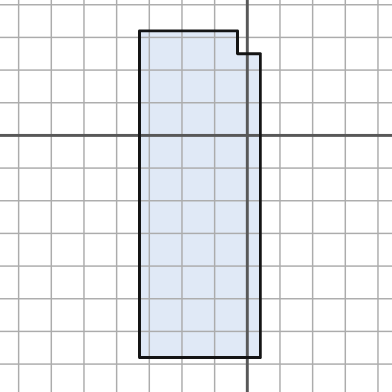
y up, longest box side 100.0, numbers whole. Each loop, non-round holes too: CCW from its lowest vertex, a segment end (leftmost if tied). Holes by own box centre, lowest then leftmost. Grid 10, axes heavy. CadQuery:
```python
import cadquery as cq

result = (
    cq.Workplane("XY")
    .moveTo(-33.0, -68.0)
    .lineTo(4.0, -68.0)
    .lineTo(4.0, 25.0)
    .lineTo(-3.0, 25.0)
    .lineTo(-3.0, 32.0)
    .lineTo(-33.0, 32.0)
    .close()
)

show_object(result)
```